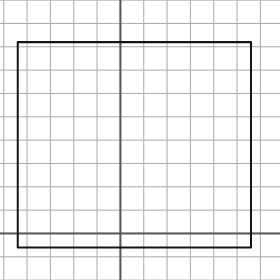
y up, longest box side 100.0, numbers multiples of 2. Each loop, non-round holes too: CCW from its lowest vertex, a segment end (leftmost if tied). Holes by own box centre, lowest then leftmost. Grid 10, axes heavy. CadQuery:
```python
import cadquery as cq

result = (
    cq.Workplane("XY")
    .moveTo(-44.0, -6.0)
    .lineTo(56.0, -6.0)
    .lineTo(56.0, 82.0)
    .lineTo(-44.0, 82.0)
    .close()
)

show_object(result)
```